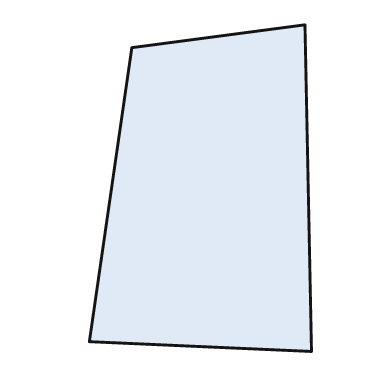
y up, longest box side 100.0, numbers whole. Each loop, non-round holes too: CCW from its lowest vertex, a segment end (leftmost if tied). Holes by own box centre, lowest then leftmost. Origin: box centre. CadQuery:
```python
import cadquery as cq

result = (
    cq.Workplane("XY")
    .moveTo(34.0, -50.0)
    .lineTo(32.0, 50.0)
    .lineTo(-21.0, 43.0)
    .lineTo(-34.0, -47.0)
    .close()
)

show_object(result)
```